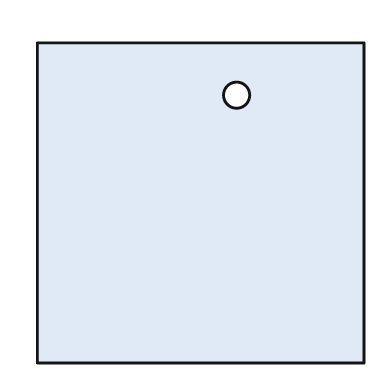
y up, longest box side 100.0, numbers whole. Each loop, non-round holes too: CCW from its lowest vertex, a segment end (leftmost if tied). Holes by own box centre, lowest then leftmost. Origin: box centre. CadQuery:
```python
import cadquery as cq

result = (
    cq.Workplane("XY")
    .moveTo(-50.0, -49.0)
    .lineTo(50.0, -49.0)
    .lineTo(50.0, 49.0)
    .lineTo(-50.0, 49.0)
    .close()
    .moveTo(11.0, 33.0)
    .circle(4.0)
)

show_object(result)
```